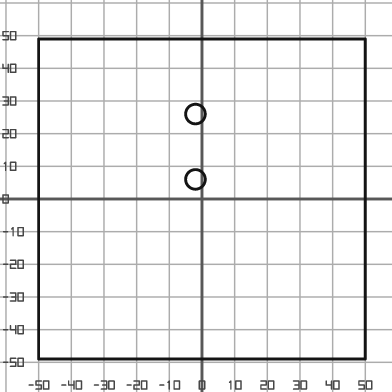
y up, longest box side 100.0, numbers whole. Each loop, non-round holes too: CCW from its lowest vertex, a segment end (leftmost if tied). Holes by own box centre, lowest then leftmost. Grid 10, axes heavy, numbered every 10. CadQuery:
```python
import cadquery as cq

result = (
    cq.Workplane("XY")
    .moveTo(-50.0, -49.0)
    .lineTo(50.0, -49.0)
    .lineTo(50.0, 49.0)
    .lineTo(-50.0, 49.0)
    .close()
    .moveTo(-2.0, 6.0)
    .circle(3.0)
    .moveTo(-2.0, 26.0)
    .circle(3.0)
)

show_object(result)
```